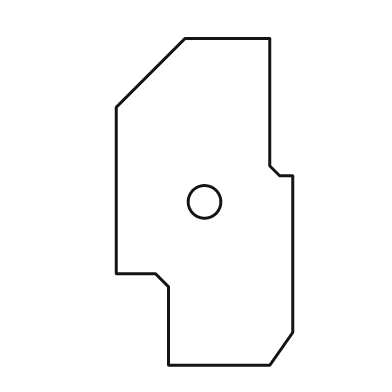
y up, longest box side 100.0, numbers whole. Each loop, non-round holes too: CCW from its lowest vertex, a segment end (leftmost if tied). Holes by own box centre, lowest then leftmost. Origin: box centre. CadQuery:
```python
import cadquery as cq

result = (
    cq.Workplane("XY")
    .moveTo(-11.0, -50.0)
    .lineTo(20.0, -50.0)
    .lineTo(27.0, -40.0)
    .lineTo(27.0, 8.0)
    .lineTo(23.0, 8.0)
    .lineTo(20.0, 11.0)
    .lineTo(20.0, 50.0)
    .lineTo(-6.0, 50.0)
    .lineTo(-27.0, 29.0)
    .lineTo(-27.0, -22.0)
    .lineTo(-15.0, -22.0)
    .lineTo(-11.0, -26.0)
    .close()
    .moveTo(0.0, 0.0)
    .circle(5.0)
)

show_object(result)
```